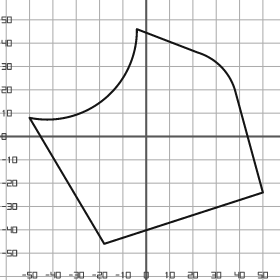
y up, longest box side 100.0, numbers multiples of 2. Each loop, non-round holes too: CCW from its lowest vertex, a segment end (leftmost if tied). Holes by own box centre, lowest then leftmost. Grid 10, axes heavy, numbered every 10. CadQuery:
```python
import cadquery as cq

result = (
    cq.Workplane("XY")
    .moveTo(-18.0, -46.0)
    .lineTo(50.0, -24.0)
    .lineTo(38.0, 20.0)
    .threePointArc((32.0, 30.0), (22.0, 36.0))
    .lineTo(-4.0, 46.0)
    .threePointArc((-18.0, 16.0), (-50.0, 8.0))
    .close()
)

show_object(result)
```